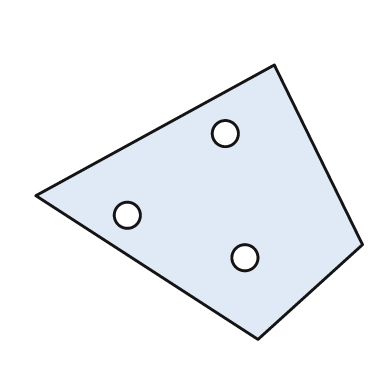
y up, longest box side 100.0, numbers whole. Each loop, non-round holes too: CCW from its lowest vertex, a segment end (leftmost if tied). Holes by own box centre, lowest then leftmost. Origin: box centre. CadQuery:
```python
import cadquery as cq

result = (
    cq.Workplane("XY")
    .moveTo(18.0, -42.0)
    .lineTo(50.0, -13.0)
    .lineTo(23.0, 42.0)
    .lineTo(-50.0, 2.0)
    .close()
    .moveTo(14.0, -17.0)
    .circle(4.0)
    .moveTo(-22.0, -4.0)
    .circle(4.0)
    .moveTo(8.0, 21.0)
    .circle(4.0)
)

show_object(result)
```